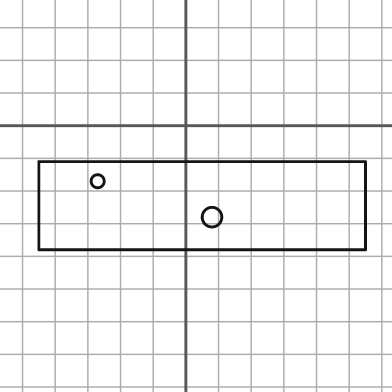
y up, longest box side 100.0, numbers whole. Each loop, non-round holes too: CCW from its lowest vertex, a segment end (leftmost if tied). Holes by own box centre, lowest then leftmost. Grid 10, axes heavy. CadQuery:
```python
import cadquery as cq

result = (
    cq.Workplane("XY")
    .moveTo(-45.0, -38.0)
    .lineTo(55.0, -38.0)
    .lineTo(55.0, -11.0)
    .lineTo(-45.0, -11.0)
    .close()
    .moveTo(8.0, -28.0)
    .circle(3.0)
    .moveTo(-27.0, -17.0)
    .circle(2.0)
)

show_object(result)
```